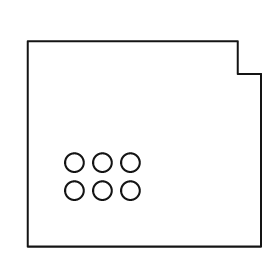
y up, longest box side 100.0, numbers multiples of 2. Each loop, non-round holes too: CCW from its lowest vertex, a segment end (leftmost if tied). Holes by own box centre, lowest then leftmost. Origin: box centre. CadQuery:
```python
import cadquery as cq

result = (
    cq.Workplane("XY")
    .moveTo(-50.0, -44.0)
    .lineTo(50.0, -44.0)
    .lineTo(50.0, 30.0)
    .lineTo(40.0, 30.0)
    .lineTo(40.0, 44.0)
    .lineTo(-50.0, 44.0)
    .close()
    .moveTo(-30.0, -20.0)
    .circle(4.0)
    .moveTo(-18.0, -20.0)
    .circle(4.0)
    .moveTo(-6.0, -20.0)
    .circle(4.0)
    .moveTo(-30.0, -8.0)
    .circle(4.0)
    .moveTo(-18.0, -8.0)
    .circle(4.0)
    .moveTo(-6.0, -8.0)
    .circle(4.0)
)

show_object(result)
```